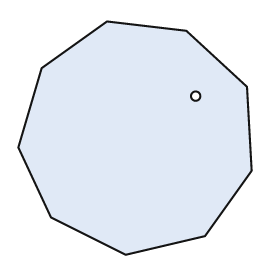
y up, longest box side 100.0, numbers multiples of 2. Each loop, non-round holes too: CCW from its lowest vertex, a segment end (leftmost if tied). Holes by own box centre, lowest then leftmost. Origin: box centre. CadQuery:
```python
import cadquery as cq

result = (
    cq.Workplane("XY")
    .moveTo(-4.0, -50.0)
    .lineTo(30.0, -42.0)
    .lineTo(50.0, -14.0)
    .lineTo(48.0, 22.0)
    .lineTo(22.0, 46.0)
    .lineTo(-12.0, 50.0)
    .lineTo(-40.0, 30.0)
    .lineTo(-50.0, -4.0)
    .lineTo(-36.0, -34.0)
    .close()
    .moveTo(26.0, 18.0)
    .circle(2.0)
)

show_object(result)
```